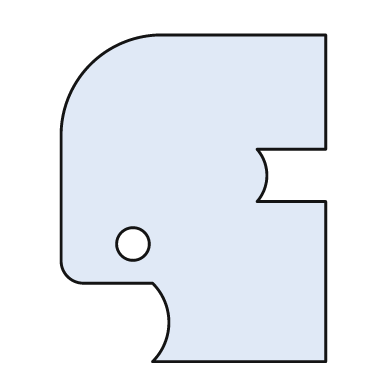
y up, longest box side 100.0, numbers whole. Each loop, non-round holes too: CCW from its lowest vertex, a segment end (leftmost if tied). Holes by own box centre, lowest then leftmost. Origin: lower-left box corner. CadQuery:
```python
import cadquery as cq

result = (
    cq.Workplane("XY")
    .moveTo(28.0, 0.0)
    .lineTo(81.0, 0.0)
    .lineTo(81.0, 49.0)
    .lineTo(60.0, 49.0)
    .threePointArc((63.0, 57.0), (60.0, 65.0))
    .lineTo(81.0, 65.0)
    .lineTo(81.0, 100.0)
    .lineTo(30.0, 100.0)
    .threePointArc((9.0, 91.0), (0.0, 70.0))
    .lineTo(0.0, 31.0)
    .threePointArc((2.0, 26.0), (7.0, 24.0))
    .lineTo(28.0, 24.0)
    .threePointArc((33.0, 12.0), (28.0, 0.0))
    .close()
    .moveTo(22.0, 36.0)
    .circle(5.0)
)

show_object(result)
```